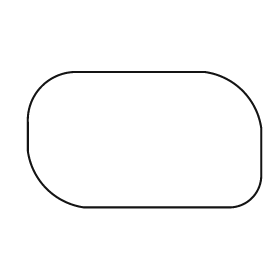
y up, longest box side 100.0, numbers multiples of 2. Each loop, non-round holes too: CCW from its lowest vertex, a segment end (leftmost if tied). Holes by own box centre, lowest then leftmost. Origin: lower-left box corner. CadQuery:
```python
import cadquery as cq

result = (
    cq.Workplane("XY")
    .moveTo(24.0, 0.0)
    .lineTo(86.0, 0.0)
    .threePointArc((96.0, 4.0), (100.0, 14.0))
    .lineTo(100.0, 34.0)
    .threePointArc((92.0, 50.0), (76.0, 58.0))
    .lineTo(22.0, 58.0)
    .threePointArc((6.0, 52.0), (0.0, 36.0))
    .lineTo(0.0, 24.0)
    .threePointArc((8.0, 8.0), (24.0, 0.0))
    .close()
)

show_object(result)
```